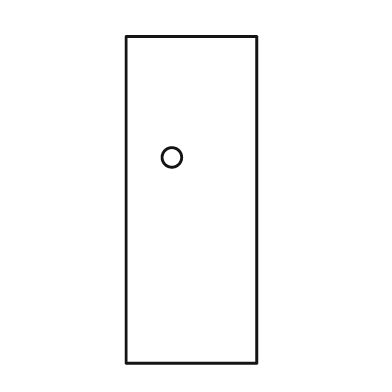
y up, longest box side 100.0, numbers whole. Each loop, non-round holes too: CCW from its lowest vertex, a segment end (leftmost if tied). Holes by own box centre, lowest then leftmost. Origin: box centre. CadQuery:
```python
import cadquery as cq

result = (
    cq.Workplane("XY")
    .moveTo(-20.0, -50.0)
    .lineTo(20.0, -50.0)
    .lineTo(20.0, 50.0)
    .lineTo(-20.0, 50.0)
    .close()
    .moveTo(-6.0, 13.0)
    .circle(3.0)
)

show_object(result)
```